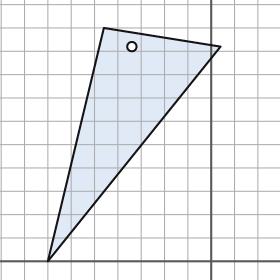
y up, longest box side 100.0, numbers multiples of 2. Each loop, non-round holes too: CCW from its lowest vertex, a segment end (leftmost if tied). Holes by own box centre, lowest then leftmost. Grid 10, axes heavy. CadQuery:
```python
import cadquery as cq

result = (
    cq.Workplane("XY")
    .moveTo(-70.0, 0.0)
    .lineTo(4.0, 92.0)
    .lineTo(-46.0, 100.0)
    .close()
    .moveTo(-34.0, 92.0)
    .circle(2.0)
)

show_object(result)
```